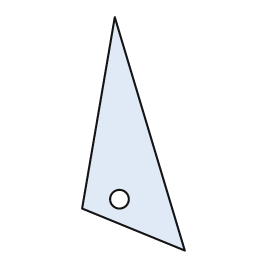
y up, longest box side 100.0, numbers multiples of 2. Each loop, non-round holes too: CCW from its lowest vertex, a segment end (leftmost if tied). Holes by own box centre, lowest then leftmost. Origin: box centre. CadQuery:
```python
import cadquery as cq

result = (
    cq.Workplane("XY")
    .moveTo(22.0, -50.0)
    .lineTo(-8.0, 50.0)
    .lineTo(-22.0, -32.0)
    .close()
    .moveTo(-6.0, -28.0)
    .circle(4.0)
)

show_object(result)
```